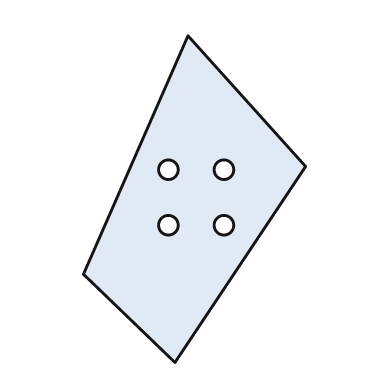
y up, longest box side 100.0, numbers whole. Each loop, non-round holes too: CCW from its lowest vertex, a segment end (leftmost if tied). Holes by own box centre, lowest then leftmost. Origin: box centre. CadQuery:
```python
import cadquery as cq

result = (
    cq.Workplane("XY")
    .moveTo(-6.0, -50.0)
    .lineTo(34.0, 10.0)
    .lineTo(-2.0, 50.0)
    .lineTo(-34.0, -23.0)
    .close()
    .moveTo(-8.0, -8.0)
    .circle(3.0)
    .moveTo(9.0, -8.0)
    .circle(3.0)
    .moveTo(-8.0, 9.0)
    .circle(3.0)
    .moveTo(9.0, 9.0)
    .circle(3.0)
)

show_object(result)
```